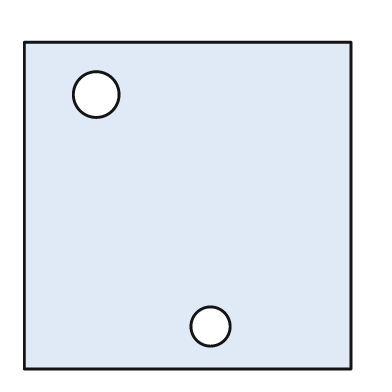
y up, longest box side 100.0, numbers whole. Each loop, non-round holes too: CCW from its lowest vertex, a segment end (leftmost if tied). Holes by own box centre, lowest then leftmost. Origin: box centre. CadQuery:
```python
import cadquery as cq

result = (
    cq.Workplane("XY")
    .moveTo(-50.0, -50.0)
    .lineTo(50.0, -50.0)
    .lineTo(50.0, 50.0)
    .lineTo(-50.0, 50.0)
    .close()
    .moveTo(7.0, -37.0)
    .circle(6.0)
    .moveTo(-28.0, 34.0)
    .circle(7.0)
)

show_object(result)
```